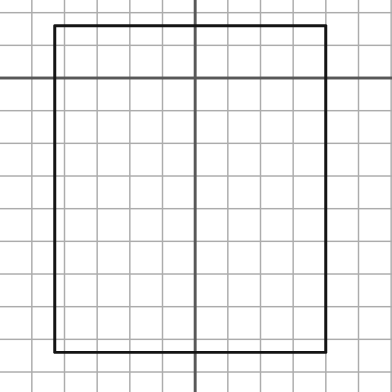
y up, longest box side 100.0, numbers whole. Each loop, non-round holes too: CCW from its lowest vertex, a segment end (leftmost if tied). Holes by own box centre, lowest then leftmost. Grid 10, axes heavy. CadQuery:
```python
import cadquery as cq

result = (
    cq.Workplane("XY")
    .moveTo(-43.0, -84.0)
    .lineTo(40.0, -84.0)
    .lineTo(40.0, 16.0)
    .lineTo(-43.0, 16.0)
    .close()
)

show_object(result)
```